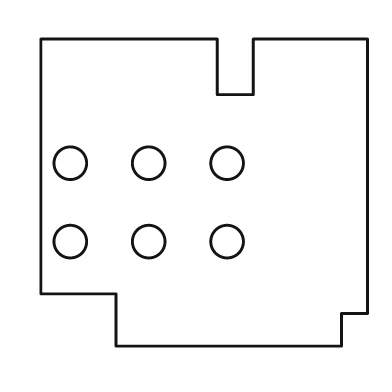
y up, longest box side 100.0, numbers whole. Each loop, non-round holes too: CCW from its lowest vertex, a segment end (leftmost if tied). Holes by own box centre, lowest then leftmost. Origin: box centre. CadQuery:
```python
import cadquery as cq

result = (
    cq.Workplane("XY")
    .moveTo(-27.0, -47.0)
    .lineTo(42.0, -47.0)
    .lineTo(42.0, -37.0)
    .lineTo(50.0, -37.0)
    .lineTo(50.0, 47.0)
    .lineTo(15.0, 47.0)
    .lineTo(15.0, 30.0)
    .lineTo(4.0, 30.0)
    .lineTo(4.0, 47.0)
    .lineTo(-50.0, 47.0)
    .lineTo(-50.0, -31.0)
    .lineTo(-27.0, -31.0)
    .close()
    .moveTo(-41.0, -15.0)
    .circle(5.0)
    .moveTo(-17.0, -15.0)
    .circle(5.0)
    .moveTo(7.0, -15.0)
    .circle(5.0)
    .moveTo(-41.0, 9.0)
    .circle(5.0)
    .moveTo(-17.0, 9.0)
    .circle(5.0)
    .moveTo(7.0, 9.0)
    .circle(5.0)
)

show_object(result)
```